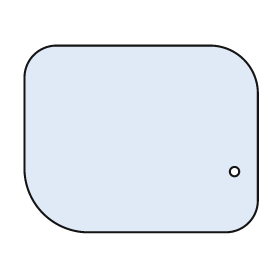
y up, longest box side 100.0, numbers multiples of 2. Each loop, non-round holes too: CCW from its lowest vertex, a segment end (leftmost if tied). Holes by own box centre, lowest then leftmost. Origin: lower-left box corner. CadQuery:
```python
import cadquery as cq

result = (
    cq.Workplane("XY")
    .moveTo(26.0, 0.0)
    .lineTo(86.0, 0.0)
    .threePointArc((96.0, 4.0), (100.0, 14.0))
    .lineTo(100.0, 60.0)
    .threePointArc((94.0, 74.0), (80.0, 80.0))
    .lineTo(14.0, 80.0)
    .threePointArc((4.0, 76.0), (0.0, 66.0))
    .lineTo(0.0, 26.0)
    .threePointArc((8.0, 8.0), (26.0, 0.0))
    .close()
    .moveTo(90.0, 26.0)
    .circle(2.0)
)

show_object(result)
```